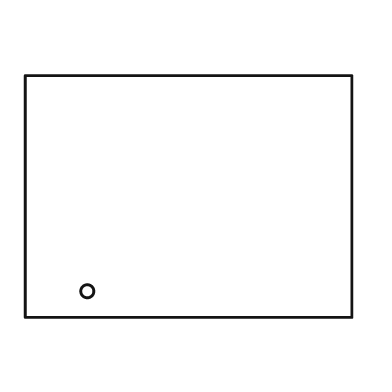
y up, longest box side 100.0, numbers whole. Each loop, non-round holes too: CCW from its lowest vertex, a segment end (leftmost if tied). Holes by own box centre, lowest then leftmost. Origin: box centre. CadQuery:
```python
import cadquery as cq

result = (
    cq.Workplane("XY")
    .moveTo(-50.0, -37.0)
    .lineTo(50.0, -37.0)
    .lineTo(50.0, 37.0)
    .lineTo(-50.0, 37.0)
    .close()
    .moveTo(-31.0, -29.0)
    .circle(2.0)
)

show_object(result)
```